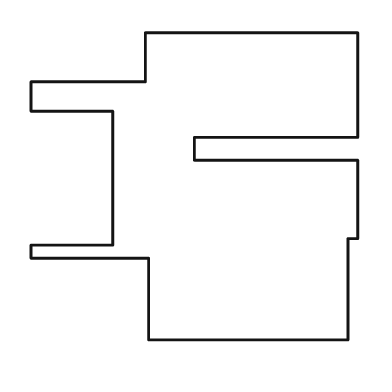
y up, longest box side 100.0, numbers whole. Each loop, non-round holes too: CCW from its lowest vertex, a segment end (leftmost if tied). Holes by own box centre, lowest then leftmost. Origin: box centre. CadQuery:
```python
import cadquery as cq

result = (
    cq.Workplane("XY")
    .moveTo(-14.0, -47.0)
    .lineTo(47.0, -47.0)
    .lineTo(47.0, -16.0)
    .lineTo(50.0, -16.0)
    .lineTo(50.0, 8.0)
    .lineTo(0.0, 8.0)
    .lineTo(0.0, 15.0)
    .lineTo(50.0, 15.0)
    .lineTo(50.0, 47.0)
    .lineTo(-15.0, 47.0)
    .lineTo(-15.0, 32.0)
    .lineTo(-50.0, 32.0)
    .lineTo(-50.0, 23.0)
    .lineTo(-25.0, 23.0)
    .lineTo(-25.0, -18.0)
    .lineTo(-50.0, -18.0)
    .lineTo(-50.0, -22.0)
    .lineTo(-14.0, -22.0)
    .close()
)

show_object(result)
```